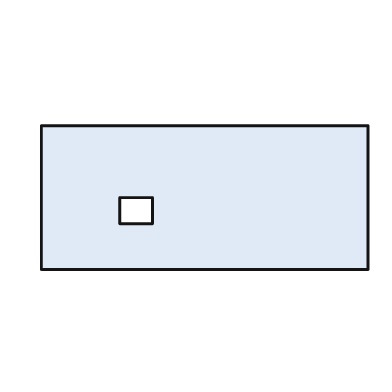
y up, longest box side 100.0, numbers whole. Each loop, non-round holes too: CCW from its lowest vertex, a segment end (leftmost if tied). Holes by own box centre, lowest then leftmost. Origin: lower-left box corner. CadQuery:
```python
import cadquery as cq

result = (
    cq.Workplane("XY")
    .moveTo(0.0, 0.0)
    .lineTo(100.0, 0.0)
    .lineTo(100.0, 44.0)
    .lineTo(0.0, 44.0)
    .close()
    .moveTo(24.0, 14.0)
    .lineTo(34.0, 14.0)
    .lineTo(34.0, 22.0)
    .lineTo(24.0, 22.0)
    .close()
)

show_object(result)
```